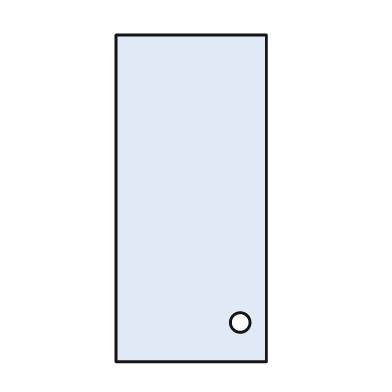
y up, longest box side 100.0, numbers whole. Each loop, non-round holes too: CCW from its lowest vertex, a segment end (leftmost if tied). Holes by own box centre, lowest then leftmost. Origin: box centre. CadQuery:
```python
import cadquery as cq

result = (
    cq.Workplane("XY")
    .moveTo(-23.0, -50.0)
    .lineTo(23.0, -50.0)
    .lineTo(23.0, 50.0)
    .lineTo(-23.0, 50.0)
    .close()
    .moveTo(15.0, -38.0)
    .circle(3.0)
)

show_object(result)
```